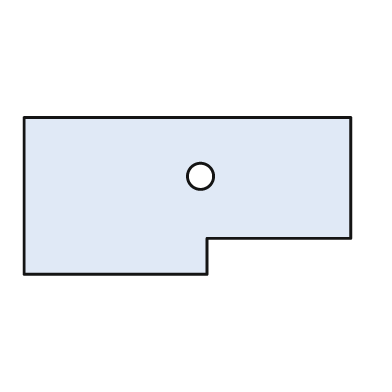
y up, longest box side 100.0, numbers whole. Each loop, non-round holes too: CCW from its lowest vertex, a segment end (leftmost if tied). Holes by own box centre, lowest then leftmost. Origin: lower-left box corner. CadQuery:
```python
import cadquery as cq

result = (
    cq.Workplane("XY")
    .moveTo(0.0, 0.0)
    .lineTo(56.0, 0.0)
    .lineTo(56.0, 11.0)
    .lineTo(100.0, 11.0)
    .lineTo(100.0, 48.0)
    .lineTo(0.0, 48.0)
    .close()
    .moveTo(54.0, 30.0)
    .circle(4.0)
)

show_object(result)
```